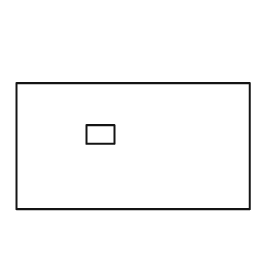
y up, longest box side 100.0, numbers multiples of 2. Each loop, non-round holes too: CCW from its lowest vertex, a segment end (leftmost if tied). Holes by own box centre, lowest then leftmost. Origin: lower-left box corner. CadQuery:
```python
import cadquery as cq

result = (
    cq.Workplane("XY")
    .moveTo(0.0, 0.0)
    .lineTo(100.0, 0.0)
    .lineTo(100.0, 54.0)
    .lineTo(0.0, 54.0)
    .close()
    .moveTo(30.0, 28.0)
    .lineTo(42.0, 28.0)
    .lineTo(42.0, 36.0)
    .lineTo(30.0, 36.0)
    .close()
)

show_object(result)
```